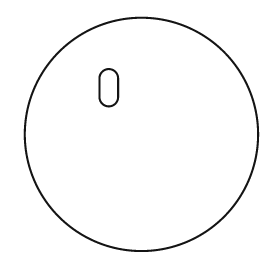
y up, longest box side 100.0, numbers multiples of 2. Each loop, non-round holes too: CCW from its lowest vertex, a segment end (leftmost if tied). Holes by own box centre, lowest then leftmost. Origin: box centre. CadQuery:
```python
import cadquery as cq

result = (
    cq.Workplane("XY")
    .moveTo(0.0, 0.0)
    .circle(50.0)
    .moveTo(-18.0, 16.0)
    .threePointArc((-14.0, 12.0), (-10.0, 16.0))
    .lineTo(-10.0, 24.0)
    .threePointArc((-14.0, 28.0), (-18.0, 24.0))
    .close()
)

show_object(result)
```